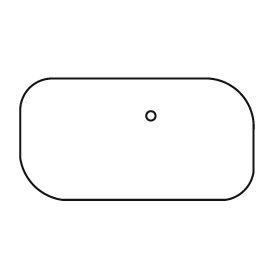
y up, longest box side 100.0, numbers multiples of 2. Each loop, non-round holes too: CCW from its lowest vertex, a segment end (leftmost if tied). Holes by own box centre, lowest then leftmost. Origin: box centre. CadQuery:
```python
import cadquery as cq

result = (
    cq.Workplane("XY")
    .moveTo(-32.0, -26.0)
    .lineTo(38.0, -26.0)
    .threePointArc((46.0, -22.0), (50.0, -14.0))
    .lineTo(50.0, 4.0)
    .threePointArc((44.0, 20.0), (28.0, 26.0))
    .lineTo(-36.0, 26.0)
    .threePointArc((-46.0, 22.0), (-50.0, 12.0))
    .lineTo(-50.0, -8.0)
    .threePointArc((-44.0, -20.0), (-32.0, -26.0))
    .close()
    .moveTo(6.0, 10.0)
    .circle(2.0)
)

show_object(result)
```